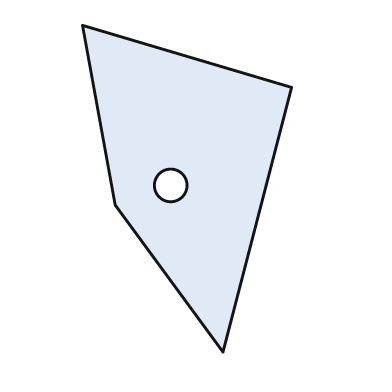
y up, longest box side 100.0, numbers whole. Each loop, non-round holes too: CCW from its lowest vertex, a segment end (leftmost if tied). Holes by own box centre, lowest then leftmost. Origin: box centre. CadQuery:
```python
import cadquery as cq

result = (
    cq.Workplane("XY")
    .moveTo(11.0, -50.0)
    .lineTo(32.0, 31.0)
    .lineTo(-32.0, 50.0)
    .lineTo(-22.0, -5.0)
    .close()
    .moveTo(-5.0, 1.0)
    .circle(5.0)
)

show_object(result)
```